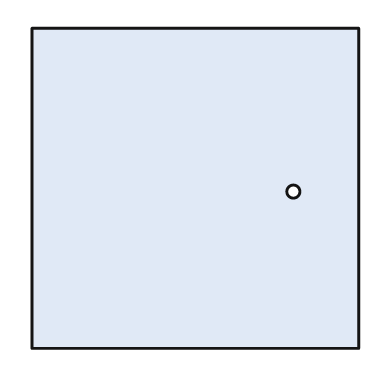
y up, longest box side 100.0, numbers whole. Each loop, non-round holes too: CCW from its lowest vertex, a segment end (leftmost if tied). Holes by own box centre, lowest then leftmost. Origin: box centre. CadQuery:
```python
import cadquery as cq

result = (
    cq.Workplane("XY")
    .moveTo(-50.0, -49.0)
    .lineTo(50.0, -49.0)
    .lineTo(50.0, 49.0)
    .lineTo(-50.0, 49.0)
    .close()
    .moveTo(30.0, -1.0)
    .circle(2.0)
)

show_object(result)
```